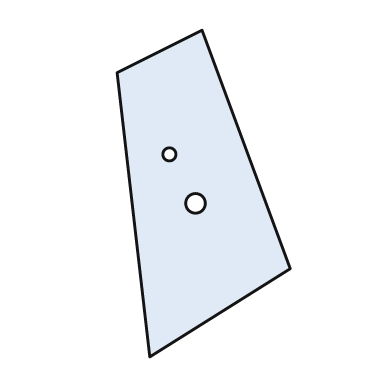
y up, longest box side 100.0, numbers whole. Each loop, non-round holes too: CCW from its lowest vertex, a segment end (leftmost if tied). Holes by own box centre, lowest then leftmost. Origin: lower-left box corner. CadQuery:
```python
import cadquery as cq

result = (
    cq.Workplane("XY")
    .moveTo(10.0, 0.0)
    .lineTo(53.0, 27.0)
    .lineTo(26.0, 100.0)
    .lineTo(0.0, 87.0)
    .close()
    .moveTo(24.0, 47.0)
    .circle(3.0)
    .moveTo(16.0, 62.0)
    .circle(2.0)
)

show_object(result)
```